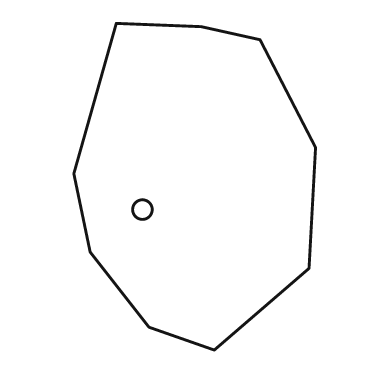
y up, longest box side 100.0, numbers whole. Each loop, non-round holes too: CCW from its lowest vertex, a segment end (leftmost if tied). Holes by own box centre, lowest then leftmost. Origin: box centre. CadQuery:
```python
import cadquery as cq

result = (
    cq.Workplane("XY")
    .moveTo(6.0, -50.0)
    .lineTo(35.0, -25.0)
    .lineTo(37.0, 12.0)
    .lineTo(20.0, 45.0)
    .lineTo(2.0, 49.0)
    .lineTo(-24.0, 50.0)
    .lineTo(-37.0, 4.0)
    .lineTo(-32.0, -20.0)
    .lineTo(-14.0, -43.0)
    .close()
    .moveTo(-16.0, -7.0)
    .circle(3.0)
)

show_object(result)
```